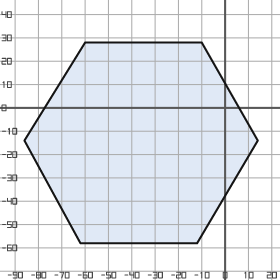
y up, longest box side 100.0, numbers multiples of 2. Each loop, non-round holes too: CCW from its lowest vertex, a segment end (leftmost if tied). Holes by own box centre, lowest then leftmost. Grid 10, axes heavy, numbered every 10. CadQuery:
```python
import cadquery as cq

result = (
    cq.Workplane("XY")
    .moveTo(-62.0, -58.0)
    .lineTo(-12.0, -58.0)
    .lineTo(14.0, -14.0)
    .lineTo(-10.0, 28.0)
    .lineTo(-60.0, 28.0)
    .lineTo(-86.0, -14.0)
    .close()
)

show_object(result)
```